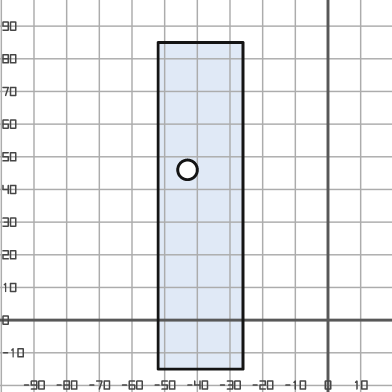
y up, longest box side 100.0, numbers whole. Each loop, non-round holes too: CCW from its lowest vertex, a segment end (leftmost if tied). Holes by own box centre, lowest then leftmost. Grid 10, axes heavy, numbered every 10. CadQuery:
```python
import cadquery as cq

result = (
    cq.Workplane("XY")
    .moveTo(-52.0, -15.0)
    .lineTo(-26.0, -15.0)
    .lineTo(-26.0, 85.0)
    .lineTo(-52.0, 85.0)
    .close()
    .moveTo(-43.0, 46.0)
    .circle(3.0)
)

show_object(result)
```